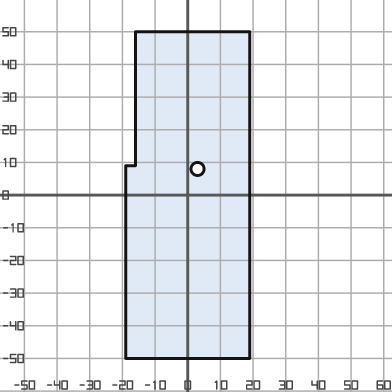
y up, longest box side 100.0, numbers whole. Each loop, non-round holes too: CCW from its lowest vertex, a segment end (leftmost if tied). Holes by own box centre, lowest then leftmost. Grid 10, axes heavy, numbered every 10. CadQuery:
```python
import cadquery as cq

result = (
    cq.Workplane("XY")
    .moveTo(-19.0, -50.0)
    .lineTo(19.0, -50.0)
    .lineTo(19.0, 50.0)
    .lineTo(-16.0, 50.0)
    .lineTo(-16.0, 9.0)
    .lineTo(-19.0, 9.0)
    .close()
    .moveTo(3.0, 8.0)
    .circle(2.0)
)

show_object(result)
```